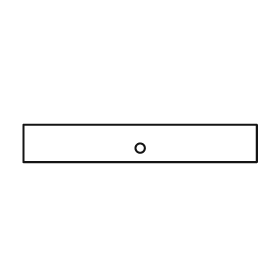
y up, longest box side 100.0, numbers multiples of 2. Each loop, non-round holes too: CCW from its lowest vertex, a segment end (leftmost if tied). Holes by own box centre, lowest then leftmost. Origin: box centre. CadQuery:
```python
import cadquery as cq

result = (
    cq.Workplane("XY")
    .moveTo(-50.0, -8.0)
    .lineTo(50.0, -8.0)
    .lineTo(50.0, 8.0)
    .lineTo(-50.0, 8.0)
    .close()
    .moveTo(0.0, -2.0)
    .circle(2.0)
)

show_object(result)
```